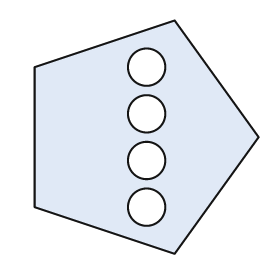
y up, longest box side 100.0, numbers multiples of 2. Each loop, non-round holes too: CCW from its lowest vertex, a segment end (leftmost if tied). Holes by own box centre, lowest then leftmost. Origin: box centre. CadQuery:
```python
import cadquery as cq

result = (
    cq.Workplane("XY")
    .moveTo(12.0, -50.0)
    .lineTo(48.0, 0.0)
    .lineTo(12.0, 50.0)
    .lineTo(-48.0, 30.0)
    .lineTo(-48.0, -30.0)
    .close()
    .moveTo(0.0, -30.0)
    .circle(8.0)
    .moveTo(0.0, -10.0)
    .circle(8.0)
    .moveTo(0.0, 10.0)
    .circle(8.0)
    .moveTo(0.0, 30.0)
    .circle(8.0)
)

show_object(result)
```